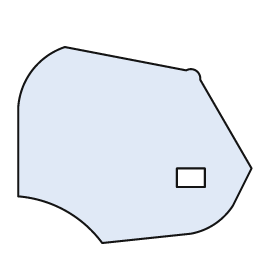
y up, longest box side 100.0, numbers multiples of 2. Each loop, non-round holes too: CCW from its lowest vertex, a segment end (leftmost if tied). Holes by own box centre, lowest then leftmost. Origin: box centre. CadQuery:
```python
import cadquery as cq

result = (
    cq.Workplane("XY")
    .moveTo(-14.0, -42.0)
    .lineTo(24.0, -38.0)
    .threePointArc((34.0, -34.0), (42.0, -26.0))
    .lineTo(50.0, -10.0)
    .lineTo(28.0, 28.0)
    .threePointArc((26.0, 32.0), (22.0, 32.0))
    .lineTo(-30.0, 42.0)
    .threePointArc((-44.0, 32.0), (-50.0, 16.0))
    .lineTo(-50.0, -22.0)
    .threePointArc((-30.0, -28.0), (-14.0, -42.0))
    .close()
    .moveTo(18.0, -18.0)
    .lineTo(30.0, -18.0)
    .lineTo(30.0, -10.0)
    .lineTo(18.0, -10.0)
    .close()
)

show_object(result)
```